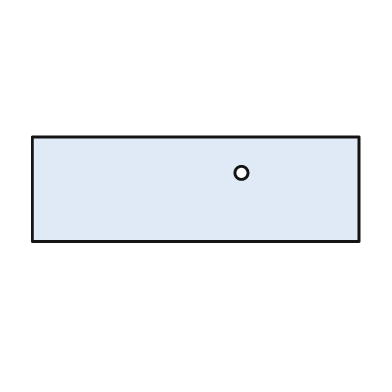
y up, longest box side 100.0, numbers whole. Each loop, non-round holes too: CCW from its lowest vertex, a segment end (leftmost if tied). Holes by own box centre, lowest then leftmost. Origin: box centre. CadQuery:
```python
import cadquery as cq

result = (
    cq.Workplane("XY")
    .moveTo(-50.0, -16.0)
    .lineTo(50.0, -16.0)
    .lineTo(50.0, 16.0)
    .lineTo(-50.0, 16.0)
    .close()
    .moveTo(14.0, 5.0)
    .circle(2.0)
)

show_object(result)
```